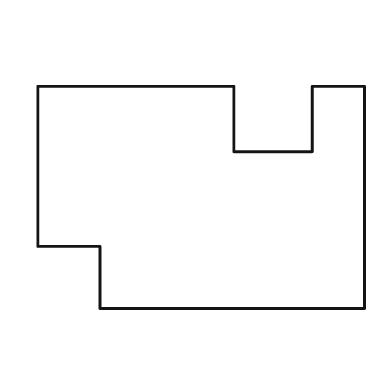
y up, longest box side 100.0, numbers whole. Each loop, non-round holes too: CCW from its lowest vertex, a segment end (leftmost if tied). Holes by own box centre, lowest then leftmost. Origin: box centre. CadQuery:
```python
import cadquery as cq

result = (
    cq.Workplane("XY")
    .moveTo(-31.0, -34.0)
    .lineTo(50.0, -34.0)
    .lineTo(50.0, 34.0)
    .lineTo(34.0, 34.0)
    .lineTo(34.0, 14.0)
    .lineTo(10.0, 14.0)
    .lineTo(10.0, 34.0)
    .lineTo(-50.0, 34.0)
    .lineTo(-50.0, -15.0)
    .lineTo(-31.0, -15.0)
    .close()
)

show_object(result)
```